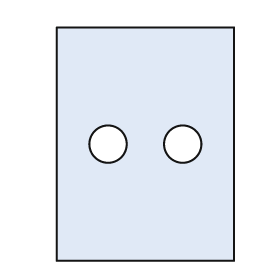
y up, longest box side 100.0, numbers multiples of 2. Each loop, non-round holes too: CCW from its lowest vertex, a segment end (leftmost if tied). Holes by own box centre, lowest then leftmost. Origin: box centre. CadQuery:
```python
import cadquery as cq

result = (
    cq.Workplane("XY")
    .moveTo(-38.0, -50.0)
    .lineTo(38.0, -50.0)
    .lineTo(38.0, 50.0)
    .lineTo(-38.0, 50.0)
    .close()
    .moveTo(-16.0, 0.0)
    .circle(8.0)
    .moveTo(16.0, 0.0)
    .circle(8.0)
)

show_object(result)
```